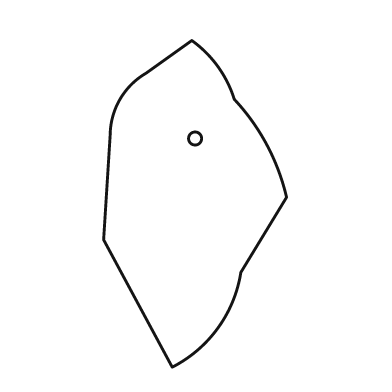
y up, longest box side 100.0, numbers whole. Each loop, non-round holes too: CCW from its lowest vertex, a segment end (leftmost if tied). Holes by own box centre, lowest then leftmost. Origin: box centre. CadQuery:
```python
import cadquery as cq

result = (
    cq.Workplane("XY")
    .moveTo(-7.0, -50.0)
    .threePointArc((7.0, -38.0), (14.0, -21.0))
    .lineTo(28.0, 2.0)
    .threePointArc((22.0, 18.0), (12.0, 32.0))
    .threePointArc((7.0, 42.0), (-1.0, 50.0))
    .lineTo(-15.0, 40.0)
    .threePointArc((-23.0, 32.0), (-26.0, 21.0))
    .lineTo(-28.0, -11.0)
    .close()
    .moveTo(0.0, 20.0)
    .circle(2.0)
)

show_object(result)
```